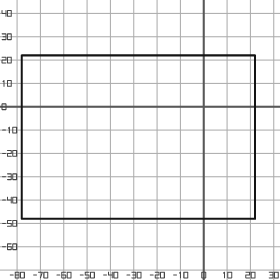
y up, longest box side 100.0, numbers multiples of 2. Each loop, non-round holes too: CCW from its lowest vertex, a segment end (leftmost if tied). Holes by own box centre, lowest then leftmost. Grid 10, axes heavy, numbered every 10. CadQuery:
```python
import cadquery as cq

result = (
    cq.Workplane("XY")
    .moveTo(-78.0, -48.0)
    .lineTo(22.0, -48.0)
    .lineTo(22.0, 22.0)
    .lineTo(-78.0, 22.0)
    .close()
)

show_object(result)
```